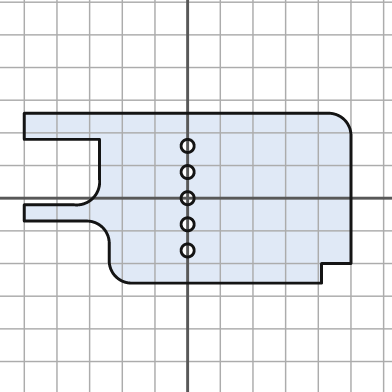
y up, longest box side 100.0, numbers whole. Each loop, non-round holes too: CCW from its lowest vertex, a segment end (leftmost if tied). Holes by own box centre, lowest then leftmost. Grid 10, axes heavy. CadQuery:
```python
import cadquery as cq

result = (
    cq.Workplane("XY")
    .moveTo(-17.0, -26.0)
    .lineTo(41.0, -26.0)
    .lineTo(41.0, -20.0)
    .lineTo(50.0, -20.0)
    .lineTo(50.0, 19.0)
    .threePointArc((48.0, 24.0), (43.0, 26.0))
    .lineTo(-50.0, 26.0)
    .lineTo(-50.0, 18.0)
    .lineTo(-27.0, 18.0)
    .lineTo(-27.0, 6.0)
    .threePointArc((-29.0, 0.0), (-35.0, -2.0))
    .lineTo(-50.0, -2.0)
    .lineTo(-50.0, -7.0)
    .lineTo(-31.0, -7.0)
    .threePointArc((-26.0, -9.0), (-24.0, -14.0))
    .lineTo(-24.0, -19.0)
    .threePointArc((-22.0, -24.0), (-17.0, -26.0))
    .close()
    .moveTo(0.0, -16.0)
    .circle(2.0)
    .moveTo(0.0, -8.0)
    .circle(2.0)
    .moveTo(0.0, 0.0)
    .circle(2.0)
    .moveTo(0.0, 8.0)
    .circle(2.0)
    .moveTo(0.0, 16.0)
    .circle(2.0)
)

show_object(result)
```